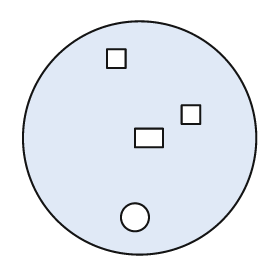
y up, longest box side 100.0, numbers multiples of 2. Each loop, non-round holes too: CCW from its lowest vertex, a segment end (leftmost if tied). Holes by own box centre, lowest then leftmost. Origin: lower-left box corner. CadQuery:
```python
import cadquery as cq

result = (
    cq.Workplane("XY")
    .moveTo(50.0, 50.0)
    .circle(50.0)
    .moveTo(48.0, 16.0)
    .circle(6.0)
    .moveTo(48.0, 46.0)
    .lineTo(60.0, 46.0)
    .lineTo(60.0, 54.0)
    .lineTo(48.0, 54.0)
    .close()
    .moveTo(68.0, 56.0)
    .lineTo(76.0, 56.0)
    .lineTo(76.0, 64.0)
    .lineTo(68.0, 64.0)
    .close()
    .moveTo(36.0, 80.0)
    .lineTo(44.0, 80.0)
    .lineTo(44.0, 88.0)
    .lineTo(36.0, 88.0)
    .close()
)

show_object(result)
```